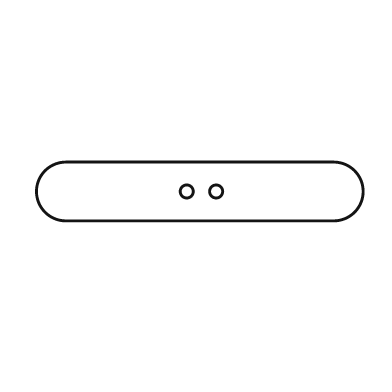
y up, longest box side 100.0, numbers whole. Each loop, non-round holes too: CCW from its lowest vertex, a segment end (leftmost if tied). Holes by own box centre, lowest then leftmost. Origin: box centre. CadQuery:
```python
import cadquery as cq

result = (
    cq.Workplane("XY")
    .moveTo(-41.0, -9.0)
    .lineTo(41.0, -9.0)
    .threePointArc((50.0, 0.0), (41.0, 9.0))
    .lineTo(-41.0, 9.0)
    .threePointArc((-50.0, 0.0), (-41.0, -9.0))
    .close()
    .moveTo(-4.0, 0.0)
    .circle(2.0)
    .moveTo(5.0, 0.0)
    .circle(2.0)
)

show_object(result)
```